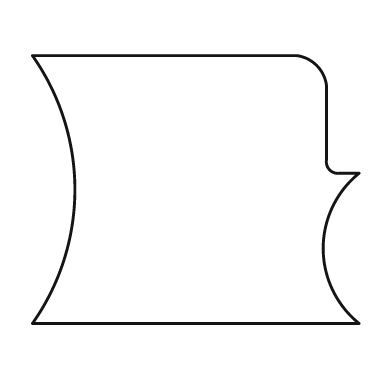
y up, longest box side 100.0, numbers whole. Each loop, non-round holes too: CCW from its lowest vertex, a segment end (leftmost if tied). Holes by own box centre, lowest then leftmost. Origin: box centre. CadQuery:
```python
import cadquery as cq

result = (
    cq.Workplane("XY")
    .moveTo(-50.0, -41.0)
    .lineTo(50.0, -41.0)
    .threePointArc((39.0, -18.0), (50.0, 5.0))
    .lineTo(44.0, 5.0)
    .threePointArc((41.0, 6.0), (40.0, 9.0))
    .lineTo(40.0, 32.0)
    .threePointArc((37.0, 38.0), (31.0, 41.0))
    .lineTo(-50.0, 41.0)
    .threePointArc((-37.0, 0.0), (-50.0, -41.0))
    .close()
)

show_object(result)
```